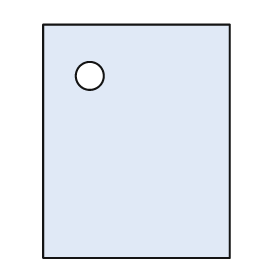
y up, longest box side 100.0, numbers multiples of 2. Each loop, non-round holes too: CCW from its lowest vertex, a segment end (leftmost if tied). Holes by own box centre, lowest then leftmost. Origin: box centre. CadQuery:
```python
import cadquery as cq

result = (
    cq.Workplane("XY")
    .moveTo(-40.0, -50.0)
    .lineTo(40.0, -50.0)
    .lineTo(40.0, 50.0)
    .lineTo(-40.0, 50.0)
    .close()
    .moveTo(-20.0, 28.0)
    .circle(6.0)
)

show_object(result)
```